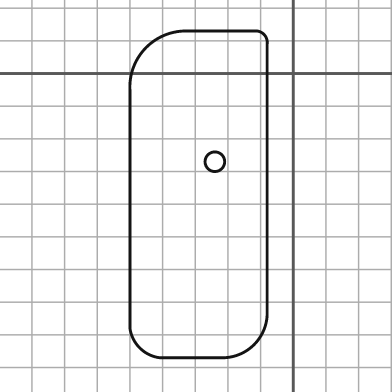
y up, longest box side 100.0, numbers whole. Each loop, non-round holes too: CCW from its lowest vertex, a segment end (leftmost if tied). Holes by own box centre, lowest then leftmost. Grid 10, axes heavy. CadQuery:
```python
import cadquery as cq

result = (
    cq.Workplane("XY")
    .moveTo(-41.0, -87.0)
    .lineTo(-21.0, -87.0)
    .threePointArc((-12.0, -83.0), (-8.0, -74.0))
    .lineTo(-8.0, 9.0)
    .threePointArc((-9.0, 12.0), (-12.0, 13.0))
    .lineTo(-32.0, 13.0)
    .threePointArc((-45.0, 8.0), (-50.0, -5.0))
    .lineTo(-50.0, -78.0)
    .threePointArc((-47.0, -84.0), (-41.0, -87.0))
    .close()
    .moveTo(-24.0, -27.0)
    .circle(3.0)
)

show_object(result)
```